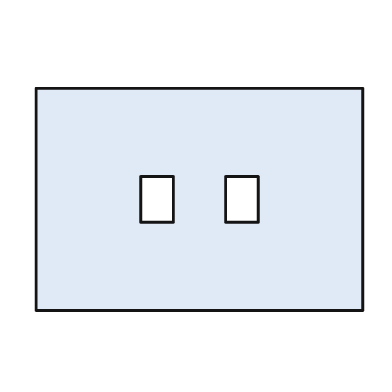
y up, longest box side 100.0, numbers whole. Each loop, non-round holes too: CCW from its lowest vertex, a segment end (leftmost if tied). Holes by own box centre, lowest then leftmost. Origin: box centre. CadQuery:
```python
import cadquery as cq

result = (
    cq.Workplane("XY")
    .moveTo(-50.0, -34.0)
    .lineTo(50.0, -34.0)
    .lineTo(50.0, 34.0)
    .lineTo(-50.0, 34.0)
    .close()
    .moveTo(-18.0, -7.0)
    .lineTo(-8.0, -7.0)
    .lineTo(-8.0, 7.0)
    .lineTo(-18.0, 7.0)
    .close()
    .moveTo(8.0, -7.0)
    .lineTo(18.0, -7.0)
    .lineTo(18.0, 7.0)
    .lineTo(8.0, 7.0)
    .close()
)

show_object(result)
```